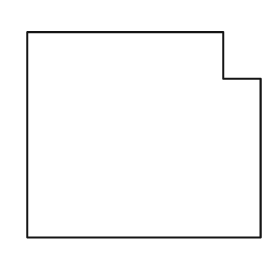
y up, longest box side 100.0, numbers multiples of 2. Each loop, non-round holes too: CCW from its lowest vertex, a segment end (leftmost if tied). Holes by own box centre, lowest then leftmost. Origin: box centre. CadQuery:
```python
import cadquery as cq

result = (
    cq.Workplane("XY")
    .moveTo(-50.0, -44.0)
    .lineTo(50.0, -44.0)
    .lineTo(50.0, 24.0)
    .lineTo(34.0, 24.0)
    .lineTo(34.0, 44.0)
    .lineTo(-50.0, 44.0)
    .close()
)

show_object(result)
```